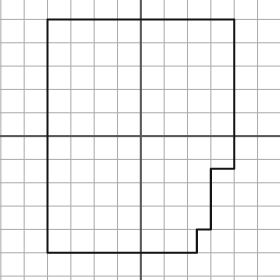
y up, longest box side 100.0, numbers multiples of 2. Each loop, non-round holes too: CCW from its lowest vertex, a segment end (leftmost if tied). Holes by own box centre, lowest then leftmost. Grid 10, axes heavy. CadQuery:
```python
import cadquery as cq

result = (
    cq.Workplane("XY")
    .moveTo(-40.0, -50.0)
    .lineTo(24.0, -50.0)
    .lineTo(24.0, -40.0)
    .lineTo(30.0, -40.0)
    .lineTo(30.0, -14.0)
    .lineTo(40.0, -14.0)
    .lineTo(40.0, 50.0)
    .lineTo(-40.0, 50.0)
    .close()
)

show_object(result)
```